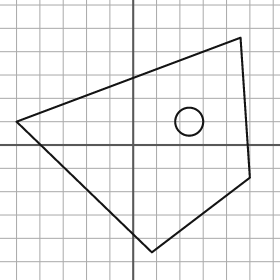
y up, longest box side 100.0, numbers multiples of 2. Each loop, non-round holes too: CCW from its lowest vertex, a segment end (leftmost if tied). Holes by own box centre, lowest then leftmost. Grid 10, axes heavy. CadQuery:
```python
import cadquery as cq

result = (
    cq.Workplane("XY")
    .moveTo(8.0, -46.0)
    .lineTo(50.0, -14.0)
    .lineTo(46.0, 46.0)
    .lineTo(-50.0, 10.0)
    .close()
    .moveTo(24.0, 10.0)
    .circle(6.0)
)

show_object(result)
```